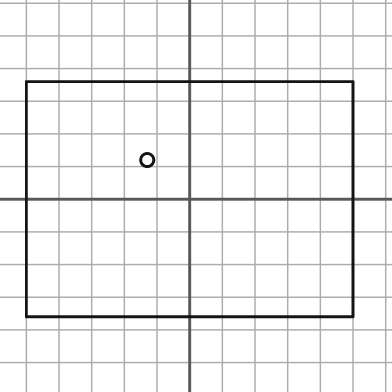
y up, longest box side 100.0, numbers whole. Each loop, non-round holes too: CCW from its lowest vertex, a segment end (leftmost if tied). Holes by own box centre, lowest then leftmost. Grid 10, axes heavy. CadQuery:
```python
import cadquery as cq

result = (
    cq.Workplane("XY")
    .moveTo(-50.0, -36.0)
    .lineTo(50.0, -36.0)
    .lineTo(50.0, 36.0)
    .lineTo(-50.0, 36.0)
    .close()
    .moveTo(-13.0, 12.0)
    .circle(2.0)
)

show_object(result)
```